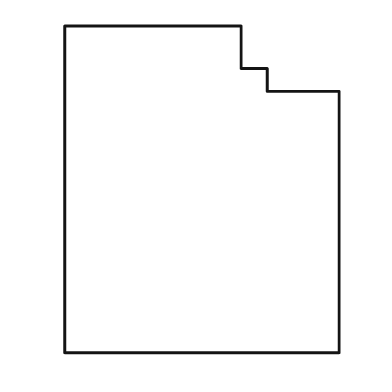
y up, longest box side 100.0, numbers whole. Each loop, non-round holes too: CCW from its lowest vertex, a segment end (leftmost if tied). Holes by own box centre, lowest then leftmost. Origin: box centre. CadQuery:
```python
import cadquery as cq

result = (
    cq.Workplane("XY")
    .moveTo(-42.0, -50.0)
    .lineTo(42.0, -50.0)
    .lineTo(42.0, 30.0)
    .lineTo(20.0, 30.0)
    .lineTo(20.0, 37.0)
    .lineTo(12.0, 37.0)
    .lineTo(12.0, 50.0)
    .lineTo(-42.0, 50.0)
    .close()
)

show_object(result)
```